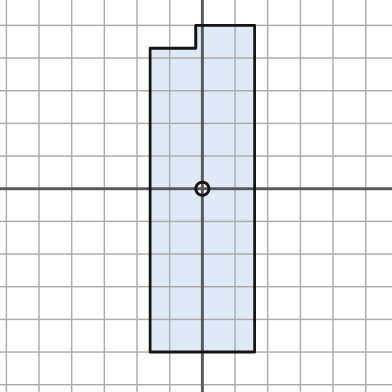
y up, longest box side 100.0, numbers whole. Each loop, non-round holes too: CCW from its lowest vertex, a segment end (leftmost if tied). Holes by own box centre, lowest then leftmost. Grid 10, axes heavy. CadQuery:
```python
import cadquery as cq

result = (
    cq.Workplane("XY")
    .moveTo(-16.0, -50.0)
    .lineTo(16.0, -50.0)
    .lineTo(16.0, 50.0)
    .lineTo(-2.0, 50.0)
    .lineTo(-2.0, 43.0)
    .lineTo(-16.0, 43.0)
    .close()
    .moveTo(0.0, 0.0)
    .circle(2.0)
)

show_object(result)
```